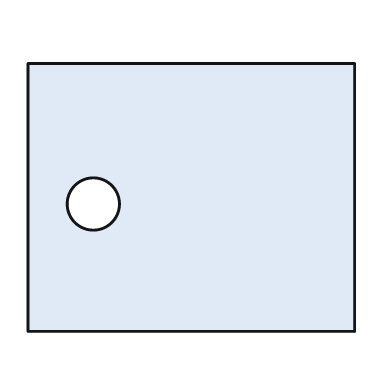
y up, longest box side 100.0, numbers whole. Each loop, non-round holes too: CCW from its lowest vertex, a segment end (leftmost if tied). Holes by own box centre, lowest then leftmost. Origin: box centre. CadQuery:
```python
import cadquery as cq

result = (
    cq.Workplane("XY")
    .moveTo(-50.0, -41.0)
    .lineTo(50.0, -41.0)
    .lineTo(50.0, 41.0)
    .lineTo(-50.0, 41.0)
    .close()
    .moveTo(-30.0, -2.0)
    .circle(8.0)
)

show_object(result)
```